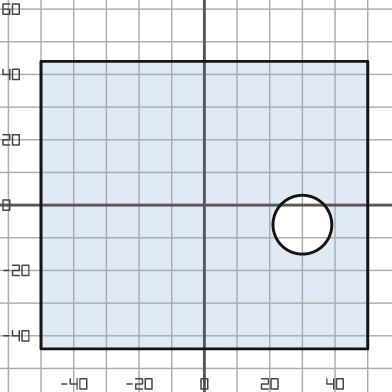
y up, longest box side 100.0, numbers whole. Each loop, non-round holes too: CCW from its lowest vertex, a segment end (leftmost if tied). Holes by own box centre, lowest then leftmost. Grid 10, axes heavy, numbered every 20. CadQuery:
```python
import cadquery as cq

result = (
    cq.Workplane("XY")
    .moveTo(-50.0, -44.0)
    .lineTo(50.0, -44.0)
    .lineTo(50.0, 44.0)
    .lineTo(-50.0, 44.0)
    .close()
    .moveTo(30.0, -6.0)
    .circle(9.0)
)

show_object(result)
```